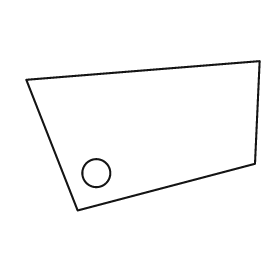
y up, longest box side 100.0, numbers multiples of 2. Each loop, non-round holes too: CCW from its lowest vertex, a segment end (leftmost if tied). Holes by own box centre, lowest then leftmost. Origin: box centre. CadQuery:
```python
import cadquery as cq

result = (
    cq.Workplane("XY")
    .moveTo(-28.0, -32.0)
    .lineTo(48.0, -12.0)
    .lineTo(50.0, 32.0)
    .lineTo(-50.0, 24.0)
    .close()
    .moveTo(-20.0, -16.0)
    .circle(6.0)
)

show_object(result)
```